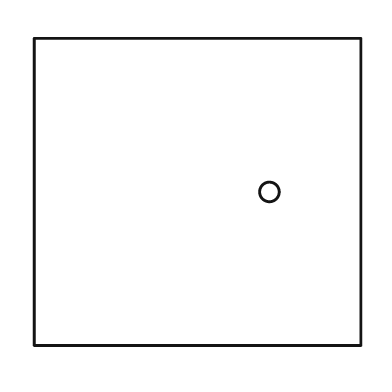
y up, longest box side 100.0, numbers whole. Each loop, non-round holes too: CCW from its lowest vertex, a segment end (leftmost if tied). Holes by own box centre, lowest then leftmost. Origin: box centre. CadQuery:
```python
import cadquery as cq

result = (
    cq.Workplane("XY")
    .moveTo(-50.0, -47.0)
    .lineTo(50.0, -47.0)
    .lineTo(50.0, 47.0)
    .lineTo(-50.0, 47.0)
    .close()
    .moveTo(22.0, 0.0)
    .circle(3.0)
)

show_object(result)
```